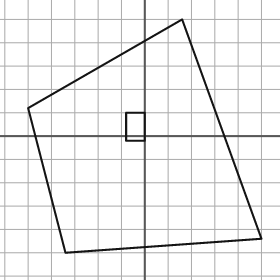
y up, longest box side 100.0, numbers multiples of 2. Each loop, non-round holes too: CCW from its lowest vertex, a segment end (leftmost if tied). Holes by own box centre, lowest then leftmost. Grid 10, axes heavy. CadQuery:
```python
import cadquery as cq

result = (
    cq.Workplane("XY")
    .moveTo(-34.0, -50.0)
    .lineTo(50.0, -44.0)
    .lineTo(16.0, 50.0)
    .lineTo(-50.0, 12.0)
    .close()
    .moveTo(-8.0, -2.0)
    .lineTo(0.0, -2.0)
    .lineTo(0.0, 10.0)
    .lineTo(-8.0, 10.0)
    .close()
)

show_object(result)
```